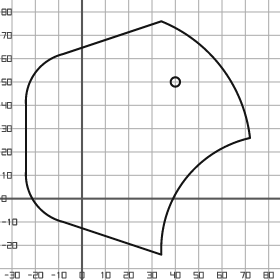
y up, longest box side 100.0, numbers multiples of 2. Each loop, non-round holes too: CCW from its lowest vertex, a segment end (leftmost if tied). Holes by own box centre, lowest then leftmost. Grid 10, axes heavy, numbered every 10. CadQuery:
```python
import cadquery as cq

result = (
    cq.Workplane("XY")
    .moveTo(34.0, -24.0)
    .threePointArc((44.0, 8.0), (72.0, 26.0))
    .threePointArc((60.0, 56.0), (34.0, 76.0))
    .lineTo(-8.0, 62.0)
    .threePointArc((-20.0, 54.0), (-24.0, 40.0))
    .lineTo(-24.0, 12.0)
    .threePointArc((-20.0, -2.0), (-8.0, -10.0))
    .close()
    .moveTo(40.0, 50.0)
    .circle(2.0)
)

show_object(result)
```